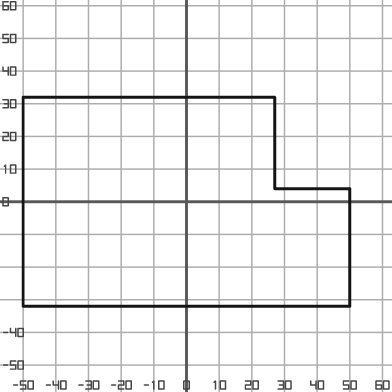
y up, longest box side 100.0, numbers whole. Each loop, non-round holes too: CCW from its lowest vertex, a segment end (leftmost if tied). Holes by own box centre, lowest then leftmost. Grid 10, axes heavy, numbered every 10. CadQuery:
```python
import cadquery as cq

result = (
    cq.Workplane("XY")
    .moveTo(-50.0, -32.0)
    .lineTo(50.0, -32.0)
    .lineTo(50.0, 4.0)
    .lineTo(27.0, 4.0)
    .lineTo(27.0, 32.0)
    .lineTo(-50.0, 32.0)
    .close()
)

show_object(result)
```